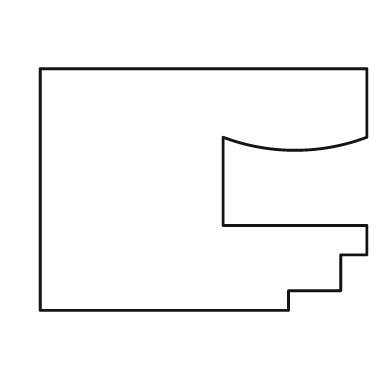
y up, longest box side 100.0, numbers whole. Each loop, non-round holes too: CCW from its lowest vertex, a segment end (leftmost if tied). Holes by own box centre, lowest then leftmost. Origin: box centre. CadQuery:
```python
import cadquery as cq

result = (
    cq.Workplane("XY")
    .moveTo(-50.0, -37.0)
    .lineTo(26.0, -37.0)
    .lineTo(26.0, -31.0)
    .lineTo(42.0, -31.0)
    .lineTo(42.0, -20.0)
    .lineTo(50.0, -20.0)
    .lineTo(50.0, -11.0)
    .lineTo(6.0, -11.0)
    .lineTo(6.0, 16.0)
    .threePointArc((28.0, 12.0), (50.0, 16.0))
    .lineTo(50.0, 37.0)
    .lineTo(-50.0, 37.0)
    .close()
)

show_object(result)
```